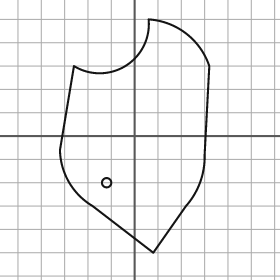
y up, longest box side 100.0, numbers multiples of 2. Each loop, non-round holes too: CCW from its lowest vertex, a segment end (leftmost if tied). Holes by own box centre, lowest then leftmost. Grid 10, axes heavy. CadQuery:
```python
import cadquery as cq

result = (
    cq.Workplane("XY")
    .moveTo(8.0, -50.0)
    .lineTo(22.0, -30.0)
    .threePointArc((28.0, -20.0), (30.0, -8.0))
    .lineTo(32.0, 30.0)
    .threePointArc((22.0, 44.0), (6.0, 50.0))
    .threePointArc((-4.0, 30.0), (-26.0, 30.0))
    .lineTo(-32.0, -6.0)
    .threePointArc((-28.0, -20.0), (-18.0, -30.0))
    .close()
    .moveTo(-12.0, -20.0)
    .circle(2.0)
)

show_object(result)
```